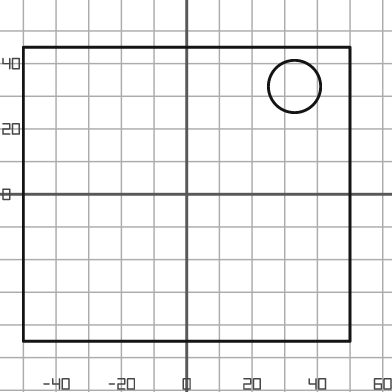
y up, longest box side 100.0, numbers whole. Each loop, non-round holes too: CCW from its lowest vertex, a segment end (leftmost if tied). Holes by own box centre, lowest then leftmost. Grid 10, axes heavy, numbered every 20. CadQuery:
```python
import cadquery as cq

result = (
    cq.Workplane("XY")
    .moveTo(-50.0, -45.0)
    .lineTo(50.0, -45.0)
    .lineTo(50.0, 45.0)
    .lineTo(-50.0, 45.0)
    .close()
    .moveTo(33.0, 33.0)
    .circle(8.0)
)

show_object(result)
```